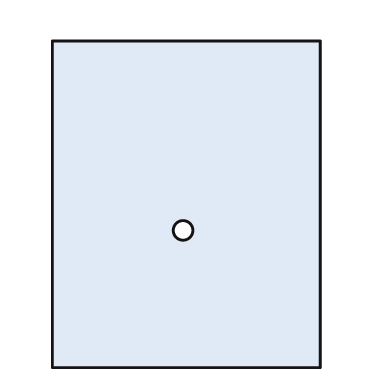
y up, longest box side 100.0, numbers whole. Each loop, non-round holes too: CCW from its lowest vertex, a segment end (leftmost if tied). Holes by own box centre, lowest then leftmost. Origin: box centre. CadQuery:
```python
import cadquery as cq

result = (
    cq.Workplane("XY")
    .moveTo(-41.0, -50.0)
    .lineTo(41.0, -50.0)
    .lineTo(41.0, 50.0)
    .lineTo(-41.0, 50.0)
    .close()
    .moveTo(-1.0, -8.0)
    .circle(3.0)
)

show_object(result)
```